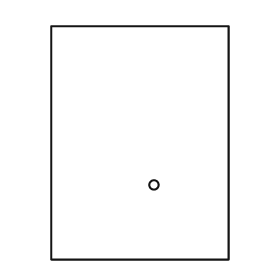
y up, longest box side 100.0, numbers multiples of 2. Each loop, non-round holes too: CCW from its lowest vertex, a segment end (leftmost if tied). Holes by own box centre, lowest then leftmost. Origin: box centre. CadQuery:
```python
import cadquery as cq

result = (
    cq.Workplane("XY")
    .moveTo(-38.0, -50.0)
    .lineTo(38.0, -50.0)
    .lineTo(38.0, 50.0)
    .lineTo(-38.0, 50.0)
    .close()
    .moveTo(6.0, -18.0)
    .circle(2.0)
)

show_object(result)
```